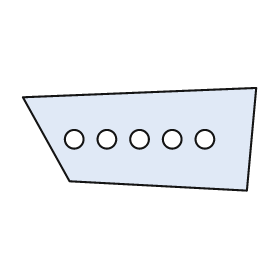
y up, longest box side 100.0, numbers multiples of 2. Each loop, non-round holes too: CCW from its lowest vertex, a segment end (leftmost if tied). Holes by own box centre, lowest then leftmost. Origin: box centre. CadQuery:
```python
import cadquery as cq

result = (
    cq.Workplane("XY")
    .moveTo(46.0, -22.0)
    .lineTo(50.0, 22.0)
    .lineTo(-50.0, 18.0)
    .lineTo(-30.0, -18.0)
    .close()
    .moveTo(-28.0, 0.0)
    .circle(4.0)
    .moveTo(-14.0, 0.0)
    .circle(4.0)
    .moveTo(0.0, 0.0)
    .circle(4.0)
    .moveTo(14.0, 0.0)
    .circle(4.0)
    .moveTo(28.0, 0.0)
    .circle(4.0)
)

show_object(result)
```